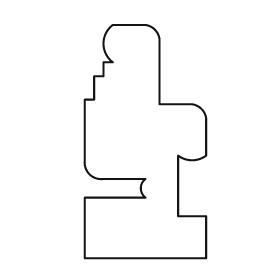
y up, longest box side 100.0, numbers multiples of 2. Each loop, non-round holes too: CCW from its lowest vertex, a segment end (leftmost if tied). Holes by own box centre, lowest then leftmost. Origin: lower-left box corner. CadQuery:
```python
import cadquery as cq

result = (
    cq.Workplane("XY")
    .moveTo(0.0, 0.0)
    .lineTo(52.0, 0.0)
    .lineTo(52.0, 18.0)
    .lineTo(40.0, 18.0)
    .lineTo(40.0, 44.0)
    .threePointArc((46.0, 42.0), (52.0, 44.0))
    .lineTo(52.0, 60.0)
    .threePointArc((50.0, 64.0), (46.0, 66.0))
    .lineTo(32.0, 66.0)
    .lineTo(32.0, 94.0)
    .threePointArc((30.0, 98.0), (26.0, 100.0))
    .lineTo(12.0, 100.0)
    .threePointArc((8.0, 92.0), (12.0, 84.0))
    .lineTo(8.0, 84.0)
    .lineTo(8.0, 78.0)
    .lineTo(4.0, 78.0)
    .lineTo(4.0, 68.0)
    .lineTo(0.0, 68.0)
    .lineTo(0.0, 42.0)
    .threePointArc((2.0, 36.0), (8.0, 34.0))
    .lineTo(26.0, 34.0)
    .threePointArc((24.0, 30.0), (26.0, 26.0))
    .lineTo(0.0, 26.0)
    .close()
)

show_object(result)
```